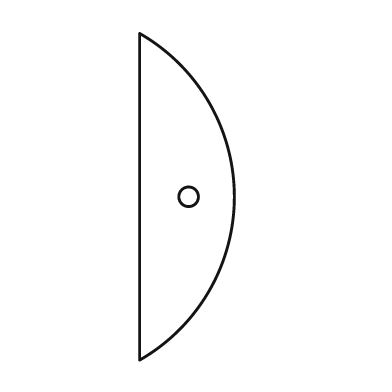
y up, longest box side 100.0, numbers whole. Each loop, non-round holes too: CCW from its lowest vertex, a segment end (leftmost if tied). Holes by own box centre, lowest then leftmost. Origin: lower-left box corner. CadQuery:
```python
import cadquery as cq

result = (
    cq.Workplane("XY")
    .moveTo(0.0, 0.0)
    .threePointArc((29.0, 50.0), (0.0, 100.0))
    .close()
    .moveTo(15.0, 50.0)
    .circle(3.0)
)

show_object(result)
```